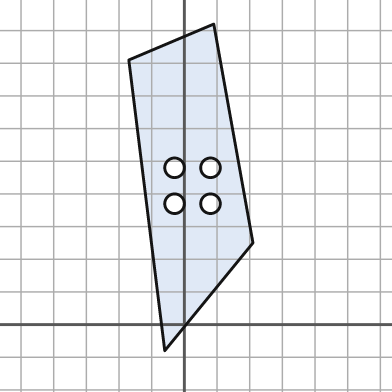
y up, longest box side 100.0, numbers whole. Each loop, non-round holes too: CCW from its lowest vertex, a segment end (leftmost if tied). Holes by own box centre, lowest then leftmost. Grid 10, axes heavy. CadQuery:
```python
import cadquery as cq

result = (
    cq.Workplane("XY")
    .moveTo(-6.0, -8.0)
    .lineTo(21.0, 25.0)
    .lineTo(9.0, 92.0)
    .lineTo(-17.0, 81.0)
    .close()
    .moveTo(-3.0, 37.0)
    .circle(3.0)
    .moveTo(8.0, 37.0)
    .circle(3.0)
    .moveTo(-3.0, 48.0)
    .circle(3.0)
    .moveTo(8.0, 48.0)
    .circle(3.0)
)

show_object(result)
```